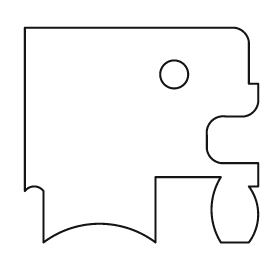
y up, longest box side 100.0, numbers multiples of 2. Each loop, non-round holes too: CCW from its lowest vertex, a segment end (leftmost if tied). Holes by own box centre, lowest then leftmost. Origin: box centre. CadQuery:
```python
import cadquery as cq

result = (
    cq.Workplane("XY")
    .moveTo(-42.0, -46.0)
    .threePointArc((-18.0, -38.0), (6.0, -46.0))
    .lineTo(6.0, -18.0)
    .lineTo(34.0, -18.0)
    .threePointArc((30.0, -32.0), (34.0, -46.0))
    .lineTo(46.0, -46.0)
    .threePointArc((50.0, -34.0), (46.0, -22.0))
    .lineTo(50.0, -22.0)
    .lineTo(50.0, -12.0)
    .lineTo(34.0, -12.0)
    .threePointArc((30.0, -10.0), (28.0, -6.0))
    .lineTo(28.0, 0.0)
    .threePointArc((30.0, 6.0), (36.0, 8.0))
    .lineTo(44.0, 8.0)
    .threePointArc((48.0, 10.0), (50.0, 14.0))
    .lineTo(50.0, 22.0)
    .lineTo(46.0, 22.0)
    .lineTo(46.0, 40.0)
    .threePointArc((44.0, 44.0), (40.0, 46.0))
    .lineTo(-50.0, 46.0)
    .lineTo(-50.0, -24.0)
    .threePointArc((-46.0, -22.0), (-42.0, -24.0))
    .close()
    .moveTo(14.0, 26.0)
    .circle(6.0)
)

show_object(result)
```